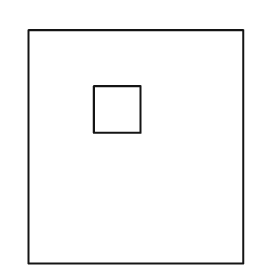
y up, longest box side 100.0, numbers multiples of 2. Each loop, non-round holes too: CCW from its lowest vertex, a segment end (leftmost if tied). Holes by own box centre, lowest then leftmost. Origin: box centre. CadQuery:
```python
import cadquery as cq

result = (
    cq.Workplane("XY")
    .moveTo(-46.0, -50.0)
    .lineTo(46.0, -50.0)
    .lineTo(46.0, 50.0)
    .lineTo(-46.0, 50.0)
    .close()
    .moveTo(-18.0, 6.0)
    .lineTo(2.0, 6.0)
    .lineTo(2.0, 26.0)
    .lineTo(-18.0, 26.0)
    .close()
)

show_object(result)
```